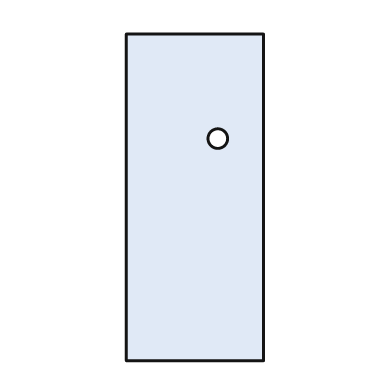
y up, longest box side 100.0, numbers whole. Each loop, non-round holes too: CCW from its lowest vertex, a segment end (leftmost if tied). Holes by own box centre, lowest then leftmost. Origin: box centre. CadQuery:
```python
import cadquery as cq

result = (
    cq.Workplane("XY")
    .moveTo(-21.0, -50.0)
    .lineTo(21.0, -50.0)
    .lineTo(21.0, 50.0)
    .lineTo(-21.0, 50.0)
    .close()
    .moveTo(7.0, 18.0)
    .circle(3.0)
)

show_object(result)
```